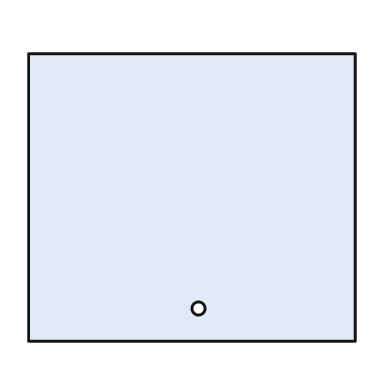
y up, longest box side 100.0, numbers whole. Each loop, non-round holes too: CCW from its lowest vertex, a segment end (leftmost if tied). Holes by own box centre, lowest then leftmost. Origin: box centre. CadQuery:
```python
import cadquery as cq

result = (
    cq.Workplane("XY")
    .moveTo(-50.0, -44.0)
    .lineTo(50.0, -44.0)
    .lineTo(50.0, 44.0)
    .lineTo(-50.0, 44.0)
    .close()
    .moveTo(2.0, -34.0)
    .circle(2.0)
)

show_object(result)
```